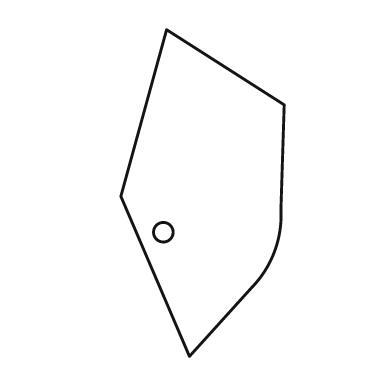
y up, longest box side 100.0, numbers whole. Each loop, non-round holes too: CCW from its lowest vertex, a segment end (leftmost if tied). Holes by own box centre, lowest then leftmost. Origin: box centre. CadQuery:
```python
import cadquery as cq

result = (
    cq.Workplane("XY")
    .moveTo(-4.0, -50.0)
    .lineTo(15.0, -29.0)
    .threePointArc((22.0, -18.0), (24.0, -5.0))
    .lineTo(25.0, 27.0)
    .lineTo(-11.0, 50.0)
    .lineTo(-25.0, -1.0)
    .close()
    .moveTo(-12.0, -12.0)
    .circle(3.0)
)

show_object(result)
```